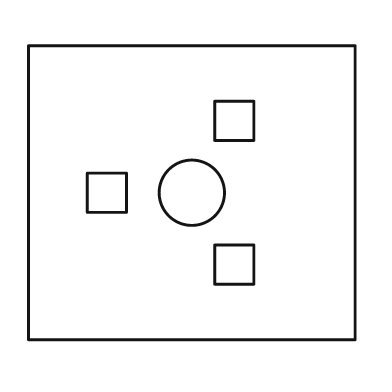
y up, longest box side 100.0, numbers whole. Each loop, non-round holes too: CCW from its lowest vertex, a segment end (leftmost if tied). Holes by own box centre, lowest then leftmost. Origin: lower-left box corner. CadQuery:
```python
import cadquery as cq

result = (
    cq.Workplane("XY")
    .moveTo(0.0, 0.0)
    .lineTo(100.0, 0.0)
    .lineTo(100.0, 90.0)
    .lineTo(0.0, 90.0)
    .close()
    .moveTo(57.0, 17.0)
    .lineTo(69.0, 17.0)
    .lineTo(69.0, 29.0)
    .lineTo(57.0, 29.0)
    .close()
    .moveTo(18.0, 39.0)
    .lineTo(30.0, 39.0)
    .lineTo(30.0, 51.0)
    .lineTo(18.0, 51.0)
    .close()
    .moveTo(50.0, 45.0)
    .circle(10.0)
    .moveTo(57.0, 61.0)
    .lineTo(69.0, 61.0)
    .lineTo(69.0, 73.0)
    .lineTo(57.0, 73.0)
    .close()
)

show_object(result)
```